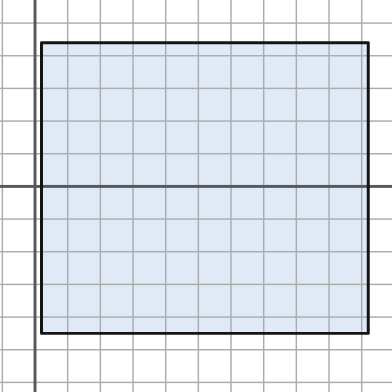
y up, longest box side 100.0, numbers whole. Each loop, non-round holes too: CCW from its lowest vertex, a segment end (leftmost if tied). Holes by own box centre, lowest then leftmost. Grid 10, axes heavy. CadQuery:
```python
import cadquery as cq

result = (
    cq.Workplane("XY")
    .moveTo(2.0, -45.0)
    .lineTo(102.0, -45.0)
    .lineTo(102.0, 44.0)
    .lineTo(2.0, 44.0)
    .close()
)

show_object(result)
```